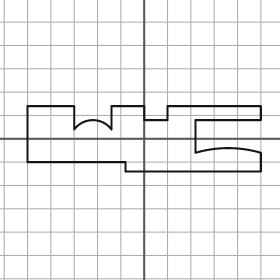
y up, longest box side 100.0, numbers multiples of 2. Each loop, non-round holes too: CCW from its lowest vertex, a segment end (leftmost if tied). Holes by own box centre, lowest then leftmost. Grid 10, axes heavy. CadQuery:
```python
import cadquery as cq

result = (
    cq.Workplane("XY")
    .moveTo(-8.0, -14.0)
    .lineTo(50.0, -14.0)
    .lineTo(50.0, -6.0)
    .threePointArc((36.0, -4.0), (22.0, -6.0))
    .lineTo(22.0, 8.0)
    .lineTo(50.0, 8.0)
    .lineTo(50.0, 14.0)
    .lineTo(10.0, 14.0)
    .lineTo(10.0, 8.0)
    .lineTo(0.0, 8.0)
    .lineTo(0.0, 14.0)
    .lineTo(-14.0, 14.0)
    .lineTo(-14.0, 4.0)
    .threePointArc((-22.0, 8.0), (-30.0, 4.0))
    .lineTo(-30.0, 14.0)
    .lineTo(-50.0, 14.0)
    .lineTo(-50.0, -10.0)
    .lineTo(-8.0, -10.0)
    .close()
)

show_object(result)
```